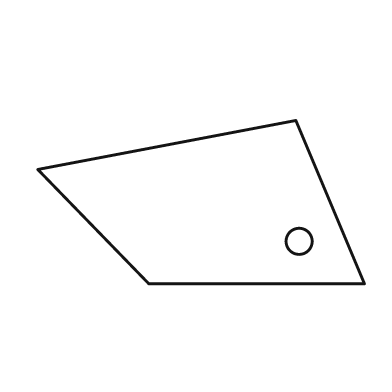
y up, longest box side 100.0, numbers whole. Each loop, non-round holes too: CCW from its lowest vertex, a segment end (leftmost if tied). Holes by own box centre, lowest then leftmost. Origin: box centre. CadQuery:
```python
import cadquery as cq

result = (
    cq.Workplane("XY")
    .moveTo(-16.0, -25.0)
    .lineTo(50.0, -25.0)
    .lineTo(29.0, 25.0)
    .lineTo(-50.0, 10.0)
    .close()
    .moveTo(30.0, -12.0)
    .circle(4.0)
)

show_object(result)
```